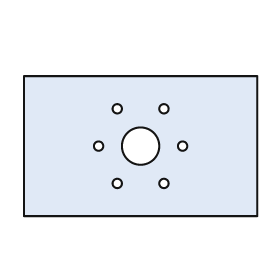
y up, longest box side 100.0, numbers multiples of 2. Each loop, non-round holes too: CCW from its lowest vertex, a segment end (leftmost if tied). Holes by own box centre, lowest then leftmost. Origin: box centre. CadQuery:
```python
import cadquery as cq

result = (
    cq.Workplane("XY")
    .moveTo(-50.0, -30.0)
    .lineTo(50.0, -30.0)
    .lineTo(50.0, 30.0)
    .lineTo(-50.0, 30.0)
    .close()
    .moveTo(-10.0, -16.0)
    .circle(2.0)
    .moveTo(10.0, -16.0)
    .circle(2.0)
    .moveTo(-18.0, 0.0)
    .circle(2.0)
    .moveTo(0.0, 0.0)
    .circle(8.0)
    .moveTo(18.0, 0.0)
    .circle(2.0)
    .moveTo(-10.0, 16.0)
    .circle(2.0)
    .moveTo(10.0, 16.0)
    .circle(2.0)
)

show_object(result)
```